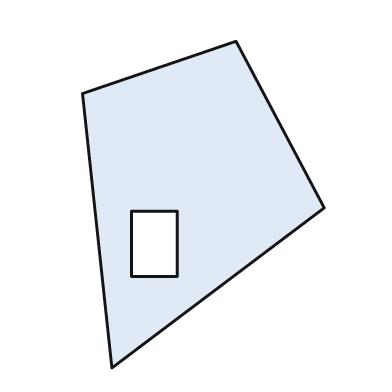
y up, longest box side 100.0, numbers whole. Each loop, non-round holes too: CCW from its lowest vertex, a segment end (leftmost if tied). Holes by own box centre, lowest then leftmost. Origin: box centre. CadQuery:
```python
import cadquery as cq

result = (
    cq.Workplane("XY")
    .moveTo(-28.0, -50.0)
    .lineTo(37.0, -1.0)
    .lineTo(10.0, 50.0)
    .lineTo(-37.0, 34.0)
    .close()
    .moveTo(-22.0, -22.0)
    .lineTo(-8.0, -22.0)
    .lineTo(-8.0, -2.0)
    .lineTo(-22.0, -2.0)
    .close()
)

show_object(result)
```